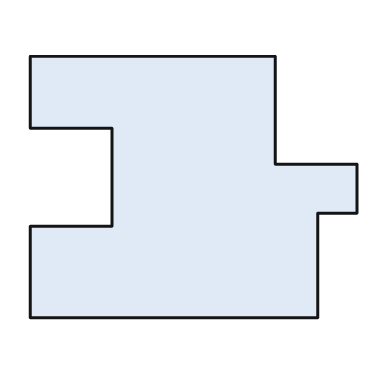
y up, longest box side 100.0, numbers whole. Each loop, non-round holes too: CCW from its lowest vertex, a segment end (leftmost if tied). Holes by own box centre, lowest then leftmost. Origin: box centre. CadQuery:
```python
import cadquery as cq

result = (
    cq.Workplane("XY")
    .moveTo(-50.0, -40.0)
    .lineTo(38.0, -40.0)
    .lineTo(38.0, -8.0)
    .lineTo(50.0, -8.0)
    .lineTo(50.0, 7.0)
    .lineTo(25.0, 7.0)
    .lineTo(25.0, 40.0)
    .lineTo(-50.0, 40.0)
    .lineTo(-50.0, 18.0)
    .lineTo(-25.0, 18.0)
    .lineTo(-25.0, -12.0)
    .lineTo(-50.0, -12.0)
    .close()
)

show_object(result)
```